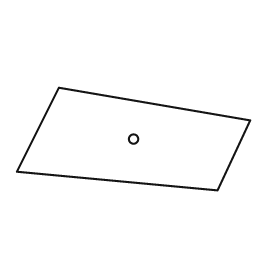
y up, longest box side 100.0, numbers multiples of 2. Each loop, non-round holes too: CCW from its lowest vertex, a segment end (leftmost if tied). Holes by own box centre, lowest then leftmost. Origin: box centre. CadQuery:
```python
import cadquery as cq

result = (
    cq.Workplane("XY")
    .moveTo(36.0, -22.0)
    .lineTo(50.0, 8.0)
    .lineTo(-32.0, 22.0)
    .lineTo(-50.0, -14.0)
    .close()
    .moveTo(0.0, 0.0)
    .circle(2.0)
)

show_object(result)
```